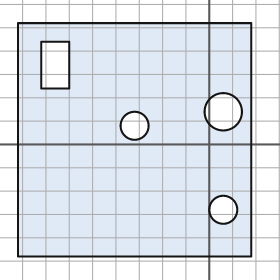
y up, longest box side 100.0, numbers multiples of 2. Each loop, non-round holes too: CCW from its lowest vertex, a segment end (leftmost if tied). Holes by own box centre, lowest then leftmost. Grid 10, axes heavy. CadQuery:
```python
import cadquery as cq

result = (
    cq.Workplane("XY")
    .moveTo(-82.0, -48.0)
    .lineTo(18.0, -48.0)
    .lineTo(18.0, 52.0)
    .lineTo(-82.0, 52.0)
    .close()
    .moveTo(6.0, -28.0)
    .circle(6.0)
    .moveTo(-32.0, 8.0)
    .circle(6.0)
    .moveTo(6.0, 14.0)
    .circle(8.0)
    .moveTo(-72.0, 24.0)
    .lineTo(-60.0, 24.0)
    .lineTo(-60.0, 44.0)
    .lineTo(-72.0, 44.0)
    .close()
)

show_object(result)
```